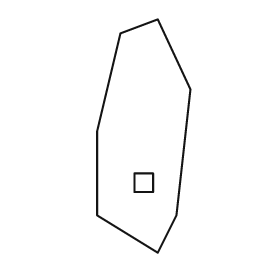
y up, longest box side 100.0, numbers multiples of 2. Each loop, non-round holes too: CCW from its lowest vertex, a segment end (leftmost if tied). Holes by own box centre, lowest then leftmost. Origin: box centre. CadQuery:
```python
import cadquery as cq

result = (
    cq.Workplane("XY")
    .moveTo(6.0, -50.0)
    .lineTo(14.0, -34.0)
    .lineTo(20.0, 20.0)
    .lineTo(6.0, 50.0)
    .lineTo(-10.0, 44.0)
    .lineTo(-20.0, 2.0)
    .lineTo(-20.0, -34.0)
    .close()
    .moveTo(-4.0, -24.0)
    .lineTo(4.0, -24.0)
    .lineTo(4.0, -16.0)
    .lineTo(-4.0, -16.0)
    .close()
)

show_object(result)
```